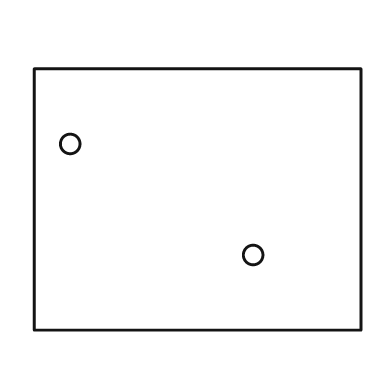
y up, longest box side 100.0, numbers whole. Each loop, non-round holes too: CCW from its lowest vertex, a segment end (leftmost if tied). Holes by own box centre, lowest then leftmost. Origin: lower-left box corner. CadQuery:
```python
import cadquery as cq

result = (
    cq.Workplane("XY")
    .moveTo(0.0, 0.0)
    .lineTo(100.0, 0.0)
    .lineTo(100.0, 80.0)
    .lineTo(0.0, 80.0)
    .close()
    .moveTo(67.0, 23.0)
    .circle(3.0)
    .moveTo(11.0, 57.0)
    .circle(3.0)
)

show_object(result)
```